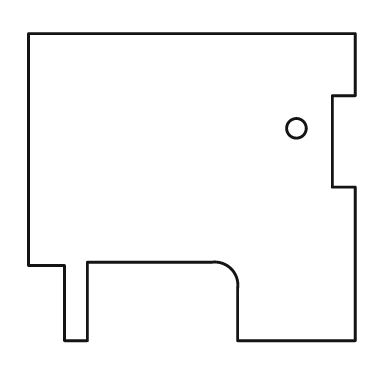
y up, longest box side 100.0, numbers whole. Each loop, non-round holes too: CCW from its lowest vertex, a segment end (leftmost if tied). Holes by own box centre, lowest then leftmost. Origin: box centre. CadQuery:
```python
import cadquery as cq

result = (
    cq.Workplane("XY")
    .moveTo(-39.0, -47.0)
    .lineTo(-32.0, -47.0)
    .lineTo(-32.0, -23.0)
    .lineTo(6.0, -23.0)
    .threePointArc((12.0, -25.0), (14.0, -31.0))
    .lineTo(14.0, -47.0)
    .lineTo(50.0, -47.0)
    .lineTo(50.0, 0.0)
    .lineTo(43.0, 0.0)
    .lineTo(43.0, 28.0)
    .lineTo(50.0, 28.0)
    .lineTo(50.0, 47.0)
    .lineTo(-50.0, 47.0)
    .lineTo(-50.0, -24.0)
    .lineTo(-39.0, -24.0)
    .close()
    .moveTo(32.0, 18.0)
    .circle(3.0)
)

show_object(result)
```